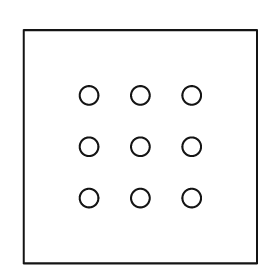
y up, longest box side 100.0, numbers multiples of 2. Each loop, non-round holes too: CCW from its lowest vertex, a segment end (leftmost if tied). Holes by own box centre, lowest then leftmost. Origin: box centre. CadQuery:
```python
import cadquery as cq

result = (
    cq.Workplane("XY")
    .moveTo(-50.0, -50.0)
    .lineTo(50.0, -50.0)
    .lineTo(50.0, 50.0)
    .lineTo(-50.0, 50.0)
    .close()
    .moveTo(-22.0, -22.0)
    .circle(4.0)
    .moveTo(0.0, -22.0)
    .circle(4.0)
    .moveTo(22.0, -22.0)
    .circle(4.0)
    .moveTo(-22.0, 0.0)
    .circle(4.0)
    .moveTo(0.0, 0.0)
    .circle(4.0)
    .moveTo(22.0, 0.0)
    .circle(4.0)
    .moveTo(-22.0, 22.0)
    .circle(4.0)
    .moveTo(0.0, 22.0)
    .circle(4.0)
    .moveTo(22.0, 22.0)
    .circle(4.0)
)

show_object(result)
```